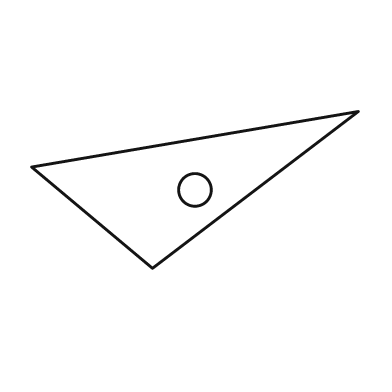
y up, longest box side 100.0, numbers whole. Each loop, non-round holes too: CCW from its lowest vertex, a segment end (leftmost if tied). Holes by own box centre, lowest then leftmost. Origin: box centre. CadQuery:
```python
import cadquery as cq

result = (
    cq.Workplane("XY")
    .moveTo(-13.0, -24.0)
    .lineTo(50.0, 24.0)
    .lineTo(-50.0, 7.0)
    .close()
    .moveTo(0.0, 0.0)
    .circle(5.0)
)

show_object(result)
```